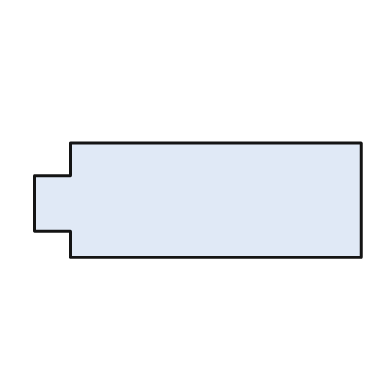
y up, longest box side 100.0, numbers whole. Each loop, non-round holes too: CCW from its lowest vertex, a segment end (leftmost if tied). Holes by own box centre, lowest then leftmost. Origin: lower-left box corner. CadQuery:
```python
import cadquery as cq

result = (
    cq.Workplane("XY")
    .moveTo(11.0, 0.0)
    .lineTo(100.0, 0.0)
    .lineTo(100.0, 35.0)
    .lineTo(11.0, 35.0)
    .lineTo(11.0, 25.0)
    .lineTo(0.0, 25.0)
    .lineTo(0.0, 8.0)
    .lineTo(11.0, 8.0)
    .close()
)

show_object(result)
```